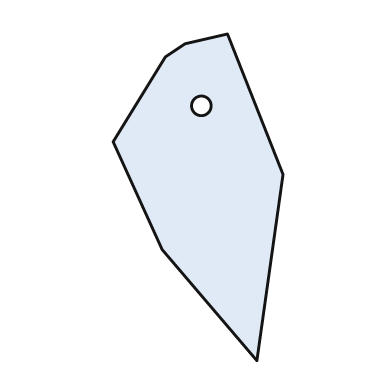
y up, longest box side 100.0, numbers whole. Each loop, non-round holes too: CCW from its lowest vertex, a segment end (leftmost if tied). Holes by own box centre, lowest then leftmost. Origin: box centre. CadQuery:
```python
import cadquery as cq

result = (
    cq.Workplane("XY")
    .moveTo(18.0, -50.0)
    .lineTo(26.0, 7.0)
    .lineTo(9.0, 50.0)
    .lineTo(-4.0, 47.0)
    .lineTo(-10.0, 43.0)
    .lineTo(-26.0, 17.0)
    .lineTo(-11.0, -16.0)
    .close()
    .moveTo(1.0, 28.0)
    .circle(3.0)
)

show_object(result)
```